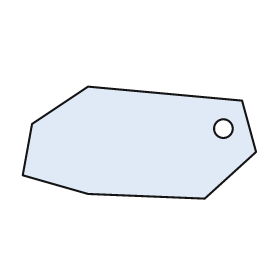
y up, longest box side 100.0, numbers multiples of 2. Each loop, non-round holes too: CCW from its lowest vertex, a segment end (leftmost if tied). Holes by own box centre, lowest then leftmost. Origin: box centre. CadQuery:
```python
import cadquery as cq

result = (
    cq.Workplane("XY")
    .moveTo(28.0, -24.0)
    .lineTo(50.0, -4.0)
    .lineTo(44.0, 18.0)
    .lineTo(-22.0, 24.0)
    .lineTo(-46.0, 8.0)
    .lineTo(-50.0, -14.0)
    .lineTo(-22.0, -22.0)
    .close()
    .moveTo(36.0, 6.0)
    .circle(4.0)
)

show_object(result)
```